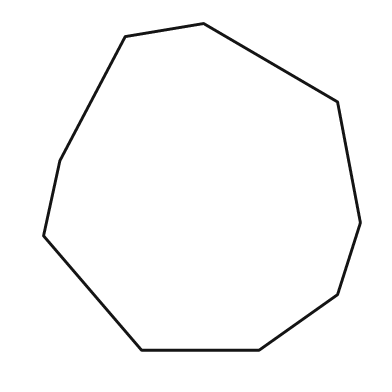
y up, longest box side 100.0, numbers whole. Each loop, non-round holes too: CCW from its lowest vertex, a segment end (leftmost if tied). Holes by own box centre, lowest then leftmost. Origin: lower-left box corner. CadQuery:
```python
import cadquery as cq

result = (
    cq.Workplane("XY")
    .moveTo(30.0, 0.0)
    .lineTo(66.0, 0.0)
    .lineTo(90.0, 17.0)
    .lineTo(97.0, 39.0)
    .lineTo(90.0, 76.0)
    .lineTo(49.0, 100.0)
    .lineTo(25.0, 96.0)
    .lineTo(5.0, 58.0)
    .lineTo(0.0, 35.0)
    .close()
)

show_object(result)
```